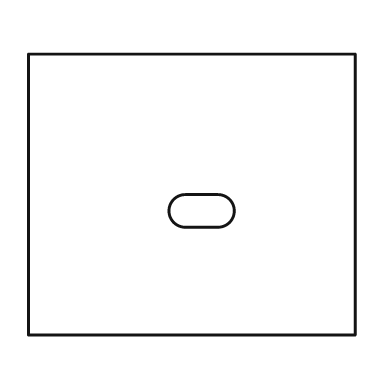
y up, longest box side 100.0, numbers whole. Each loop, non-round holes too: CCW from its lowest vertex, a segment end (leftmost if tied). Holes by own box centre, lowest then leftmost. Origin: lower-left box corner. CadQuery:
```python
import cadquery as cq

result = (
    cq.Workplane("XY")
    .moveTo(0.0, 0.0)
    .lineTo(100.0, 0.0)
    .lineTo(100.0, 86.0)
    .lineTo(0.0, 86.0)
    .close()
    .moveTo(48.0, 33.0)
    .lineTo(58.0, 33.0)
    .threePointArc((63.0, 38.0), (58.0, 43.0))
    .lineTo(48.0, 43.0)
    .threePointArc((43.0, 38.0), (48.0, 33.0))
    .close()
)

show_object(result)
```